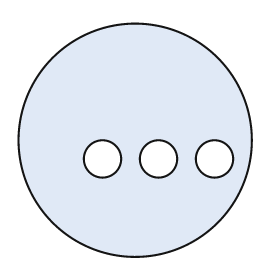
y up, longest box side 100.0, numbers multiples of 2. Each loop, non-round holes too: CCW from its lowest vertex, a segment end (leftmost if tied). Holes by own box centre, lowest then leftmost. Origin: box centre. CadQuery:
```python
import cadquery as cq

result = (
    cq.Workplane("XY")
    .moveTo(0.0, 0.0)
    .circle(50.0)
    .moveTo(-14.0, -8.0)
    .circle(8.0)
    .moveTo(10.0, -8.0)
    .circle(8.0)
    .moveTo(34.0, -8.0)
    .circle(8.0)
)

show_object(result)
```